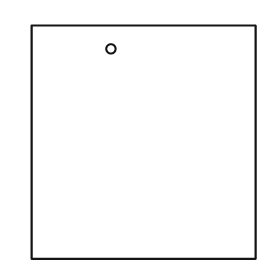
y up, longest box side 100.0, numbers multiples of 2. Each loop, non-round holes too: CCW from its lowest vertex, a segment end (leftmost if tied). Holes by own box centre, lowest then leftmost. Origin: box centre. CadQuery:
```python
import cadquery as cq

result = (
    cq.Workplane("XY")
    .moveTo(-48.0, -50.0)
    .lineTo(48.0, -50.0)
    .lineTo(48.0, 50.0)
    .lineTo(-48.0, 50.0)
    .close()
    .moveTo(-14.0, 40.0)
    .circle(2.0)
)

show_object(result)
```